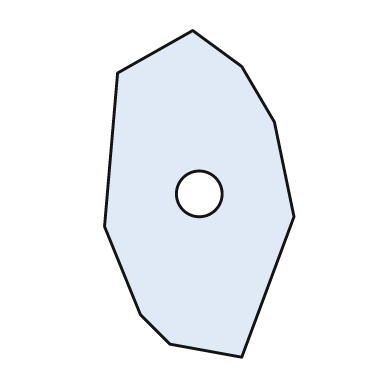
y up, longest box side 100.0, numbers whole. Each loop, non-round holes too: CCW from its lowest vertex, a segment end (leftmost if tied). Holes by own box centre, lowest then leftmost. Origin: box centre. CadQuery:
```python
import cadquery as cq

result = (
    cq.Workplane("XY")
    .moveTo(13.0, -50.0)
    .lineTo(29.0, -7.0)
    .lineTo(23.0, 22.0)
    .lineTo(13.0, 39.0)
    .lineTo(-2.0, 50.0)
    .lineTo(-25.0, 37.0)
    .lineTo(-29.0, -10.0)
    .lineTo(-18.0, -37.0)
    .lineTo(-9.0, -46.0)
    .close()
    .moveTo(0.0, 0.0)
    .circle(7.0)
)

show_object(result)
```